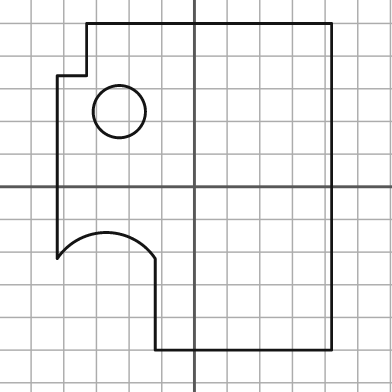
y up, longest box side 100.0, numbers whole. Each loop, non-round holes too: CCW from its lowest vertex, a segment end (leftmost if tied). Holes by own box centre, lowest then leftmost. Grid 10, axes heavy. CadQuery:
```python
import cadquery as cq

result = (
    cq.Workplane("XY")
    .moveTo(-12.0, -50.0)
    .lineTo(42.0, -50.0)
    .lineTo(42.0, 50.0)
    .lineTo(-33.0, 50.0)
    .lineTo(-33.0, 34.0)
    .lineTo(-42.0, 34.0)
    .lineTo(-42.0, -22.0)
    .threePointArc((-27.0, -14.0), (-12.0, -22.0))
    .close()
    .moveTo(-23.0, 23.0)
    .circle(8.0)
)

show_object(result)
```